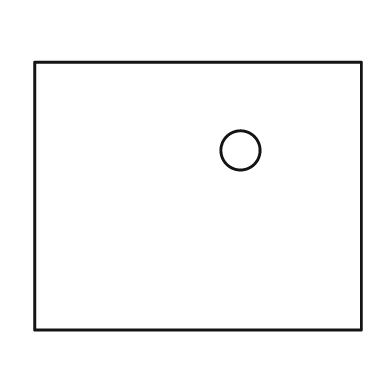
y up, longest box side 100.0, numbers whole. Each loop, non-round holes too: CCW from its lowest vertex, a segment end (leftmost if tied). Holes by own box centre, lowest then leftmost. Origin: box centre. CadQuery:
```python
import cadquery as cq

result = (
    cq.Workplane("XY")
    .moveTo(-50.0, -41.0)
    .lineTo(50.0, -41.0)
    .lineTo(50.0, 41.0)
    .lineTo(-50.0, 41.0)
    .close()
    .moveTo(13.0, 14.0)
    .circle(6.0)
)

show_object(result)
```